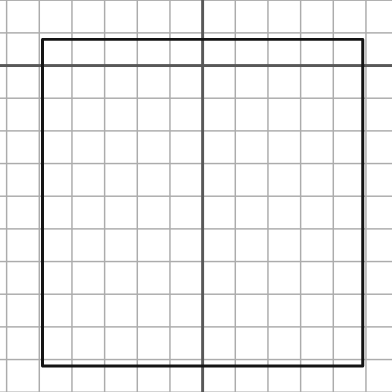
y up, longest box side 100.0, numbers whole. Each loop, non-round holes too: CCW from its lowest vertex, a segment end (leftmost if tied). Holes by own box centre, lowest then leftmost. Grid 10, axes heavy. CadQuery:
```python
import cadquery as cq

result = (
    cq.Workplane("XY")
    .moveTo(-49.0, -92.0)
    .lineTo(49.0, -92.0)
    .lineTo(49.0, 8.0)
    .lineTo(-49.0, 8.0)
    .close()
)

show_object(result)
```